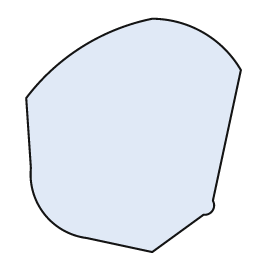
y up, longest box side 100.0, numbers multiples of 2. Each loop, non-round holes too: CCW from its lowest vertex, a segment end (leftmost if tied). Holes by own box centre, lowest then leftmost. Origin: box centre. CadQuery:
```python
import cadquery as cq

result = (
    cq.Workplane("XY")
    .moveTo(8.0, -50.0)
    .lineTo(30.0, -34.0)
    .threePointArc((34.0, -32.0), (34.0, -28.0))
    .lineTo(46.0, 28.0)
    .threePointArc((30.0, 44.0), (8.0, 50.0))
    .threePointArc((-22.0, 38.0), (-46.0, 16.0))
    .lineTo(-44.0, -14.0)
    .threePointArc((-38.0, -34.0), (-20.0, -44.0))
    .close()
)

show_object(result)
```